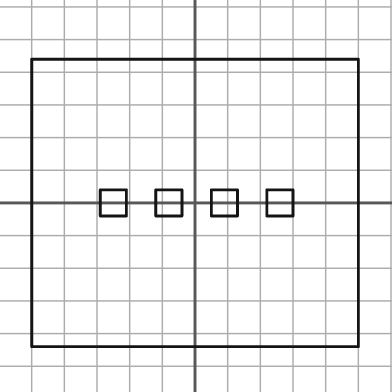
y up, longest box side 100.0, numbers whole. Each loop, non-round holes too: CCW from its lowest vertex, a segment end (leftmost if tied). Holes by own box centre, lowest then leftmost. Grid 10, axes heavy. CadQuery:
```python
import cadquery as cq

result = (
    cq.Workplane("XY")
    .moveTo(-50.0, -44.0)
    .lineTo(50.0, -44.0)
    .lineTo(50.0, 44.0)
    .lineTo(-50.0, 44.0)
    .close()
    .moveTo(-29.0, -4.0)
    .lineTo(-21.0, -4.0)
    .lineTo(-21.0, 4.0)
    .lineTo(-29.0, 4.0)
    .close()
    .moveTo(-12.0, -4.0)
    .lineTo(-4.0, -4.0)
    .lineTo(-4.0, 4.0)
    .lineTo(-12.0, 4.0)
    .close()
    .moveTo(5.0, -4.0)
    .lineTo(13.0, -4.0)
    .lineTo(13.0, 4.0)
    .lineTo(5.0, 4.0)
    .close()
    .moveTo(22.0, -4.0)
    .lineTo(30.0, -4.0)
    .lineTo(30.0, 4.0)
    .lineTo(22.0, 4.0)
    .close()
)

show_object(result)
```